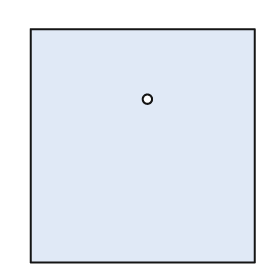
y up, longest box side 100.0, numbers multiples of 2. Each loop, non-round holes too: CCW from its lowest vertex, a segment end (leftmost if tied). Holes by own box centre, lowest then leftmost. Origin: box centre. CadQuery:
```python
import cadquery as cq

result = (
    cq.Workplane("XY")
    .moveTo(-48.0, -50.0)
    .lineTo(48.0, -50.0)
    .lineTo(48.0, 50.0)
    .lineTo(-48.0, 50.0)
    .close()
    .moveTo(2.0, 20.0)
    .circle(2.0)
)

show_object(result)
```